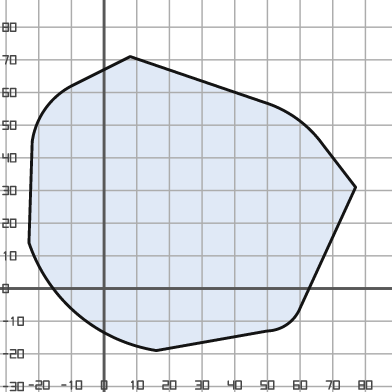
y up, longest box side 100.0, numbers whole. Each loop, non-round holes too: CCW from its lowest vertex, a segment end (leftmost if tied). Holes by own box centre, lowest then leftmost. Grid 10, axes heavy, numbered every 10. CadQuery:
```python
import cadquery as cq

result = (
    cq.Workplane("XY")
    .moveTo(16.0, -19.0)
    .lineTo(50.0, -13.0)
    .threePointArc((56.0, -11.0), (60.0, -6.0))
    .lineTo(77.0, 31.0)
    .lineTo(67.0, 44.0)
    .threePointArc((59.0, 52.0), (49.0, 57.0))
    .lineTo(8.0, 71.0)
    .lineTo(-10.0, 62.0)
    .threePointArc((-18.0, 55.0), (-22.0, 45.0))
    .lineTo(-23.0, 14.0)
    .threePointArc((-8.0, -8.0), (16.0, -19.0))
    .close()
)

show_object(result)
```